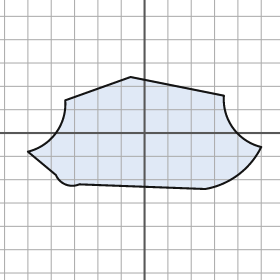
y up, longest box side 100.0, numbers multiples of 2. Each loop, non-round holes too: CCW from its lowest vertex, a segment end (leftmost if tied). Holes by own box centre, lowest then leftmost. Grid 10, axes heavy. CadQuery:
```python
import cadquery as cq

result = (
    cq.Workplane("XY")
    .moveTo(26.0, -24.0)
    .threePointArc((40.0, -18.0), (50.0, -6.0))
    .threePointArc((38.0, 2.0), (34.0, 16.0))
    .lineTo(-6.0, 24.0)
    .lineTo(-34.0, 14.0)
    .threePointArc((-38.0, 0.0), (-50.0, -8.0))
    .lineTo(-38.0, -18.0)
    .threePointArc((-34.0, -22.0), (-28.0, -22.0))
    .close()
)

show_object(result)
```